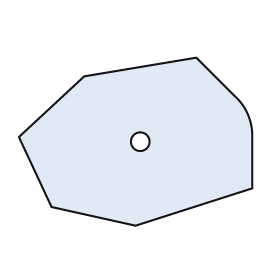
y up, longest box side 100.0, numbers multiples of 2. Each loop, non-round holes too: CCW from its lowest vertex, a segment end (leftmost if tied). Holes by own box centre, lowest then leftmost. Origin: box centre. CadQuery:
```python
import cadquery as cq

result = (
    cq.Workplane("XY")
    .moveTo(0.0, -36.0)
    .lineTo(50.0, -20.0)
    .lineTo(50.0, 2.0)
    .threePointArc((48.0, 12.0), (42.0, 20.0))
    .lineTo(26.0, 36.0)
    .lineTo(-22.0, 28.0)
    .lineTo(-50.0, 2.0)
    .lineTo(-36.0, -28.0)
    .close()
    .moveTo(2.0, 0.0)
    .circle(4.0)
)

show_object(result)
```